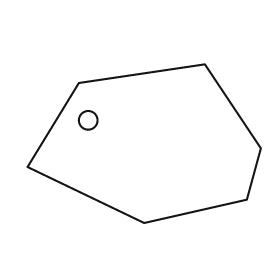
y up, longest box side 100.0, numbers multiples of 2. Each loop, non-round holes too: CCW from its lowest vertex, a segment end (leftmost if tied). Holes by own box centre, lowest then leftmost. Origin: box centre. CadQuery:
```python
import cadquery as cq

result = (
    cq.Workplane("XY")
    .moveTo(0.0, -34.0)
    .lineTo(44.0, -24.0)
    .lineTo(50.0, -2.0)
    .lineTo(26.0, 34.0)
    .lineTo(-28.0, 26.0)
    .lineTo(-50.0, -10.0)
    .close()
    .moveTo(-24.0, 10.0)
    .circle(4.0)
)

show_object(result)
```